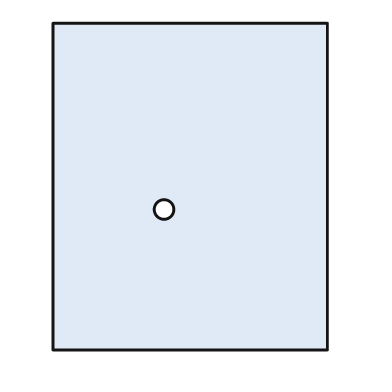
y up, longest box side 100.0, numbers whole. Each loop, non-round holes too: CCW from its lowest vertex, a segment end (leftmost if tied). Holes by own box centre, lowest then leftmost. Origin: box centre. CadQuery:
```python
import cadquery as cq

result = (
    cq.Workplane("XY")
    .moveTo(-42.0, -50.0)
    .lineTo(42.0, -50.0)
    .lineTo(42.0, 50.0)
    .lineTo(-42.0, 50.0)
    .close()
    .moveTo(-8.0, -7.0)
    .circle(3.0)
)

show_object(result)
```